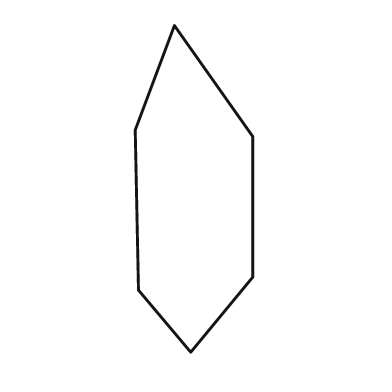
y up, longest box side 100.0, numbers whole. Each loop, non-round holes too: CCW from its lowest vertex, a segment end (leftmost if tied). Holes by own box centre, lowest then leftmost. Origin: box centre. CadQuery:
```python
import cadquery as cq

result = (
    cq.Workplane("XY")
    .moveTo(-1.0, -50.0)
    .lineTo(18.0, -27.0)
    .lineTo(18.0, 16.0)
    .lineTo(-6.0, 50.0)
    .lineTo(-18.0, 18.0)
    .lineTo(-17.0, -31.0)
    .close()
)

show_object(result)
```